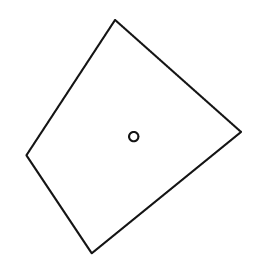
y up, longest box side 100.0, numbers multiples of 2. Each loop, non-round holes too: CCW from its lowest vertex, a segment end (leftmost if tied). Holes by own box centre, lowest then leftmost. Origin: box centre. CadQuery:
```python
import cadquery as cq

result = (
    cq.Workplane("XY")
    .moveTo(-18.0, -50.0)
    .lineTo(46.0, 2.0)
    .lineTo(-8.0, 50.0)
    .lineTo(-46.0, -8.0)
    .close()
    .moveTo(0.0, 0.0)
    .circle(2.0)
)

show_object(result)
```